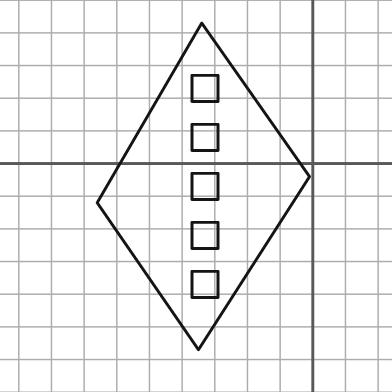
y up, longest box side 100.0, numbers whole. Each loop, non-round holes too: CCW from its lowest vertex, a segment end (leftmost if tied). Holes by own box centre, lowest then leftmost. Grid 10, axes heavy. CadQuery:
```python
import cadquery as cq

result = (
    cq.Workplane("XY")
    .moveTo(-35.0, -57.0)
    .lineTo(-1.0, -4.0)
    .lineTo(-34.0, 43.0)
    .lineTo(-66.0, -12.0)
    .close()
    .moveTo(-37.0, -41.0)
    .lineTo(-29.0, -41.0)
    .lineTo(-29.0, -33.0)
    .lineTo(-37.0, -33.0)
    .close()
    .moveTo(-37.0, -26.0)
    .lineTo(-29.0, -26.0)
    .lineTo(-29.0, -18.0)
    .lineTo(-37.0, -18.0)
    .close()
    .moveTo(-37.0, -11.0)
    .lineTo(-29.0, -11.0)
    .lineTo(-29.0, -3.0)
    .lineTo(-37.0, -3.0)
    .close()
    .moveTo(-37.0, 4.0)
    .lineTo(-29.0, 4.0)
    .lineTo(-29.0, 12.0)
    .lineTo(-37.0, 12.0)
    .close()
    .moveTo(-37.0, 19.0)
    .lineTo(-29.0, 19.0)
    .lineTo(-29.0, 27.0)
    .lineTo(-37.0, 27.0)
    .close()
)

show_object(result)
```